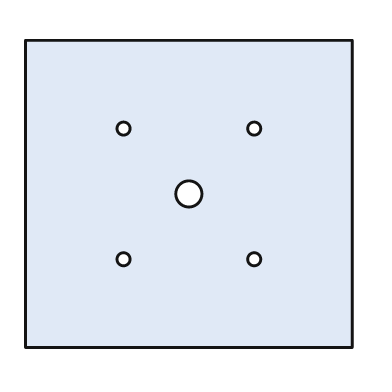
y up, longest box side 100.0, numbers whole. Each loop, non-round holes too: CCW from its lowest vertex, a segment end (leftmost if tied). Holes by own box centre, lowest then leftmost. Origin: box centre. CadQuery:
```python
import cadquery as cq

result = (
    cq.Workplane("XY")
    .moveTo(-50.0, -47.0)
    .lineTo(50.0, -47.0)
    .lineTo(50.0, 47.0)
    .lineTo(-50.0, 47.0)
    .close()
    .moveTo(-20.0, -20.0)
    .circle(2.0)
    .moveTo(20.0, -20.0)
    .circle(2.0)
    .moveTo(0.0, 0.0)
    .circle(4.0)
    .moveTo(-20.0, 20.0)
    .circle(2.0)
    .moveTo(20.0, 20.0)
    .circle(2.0)
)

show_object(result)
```